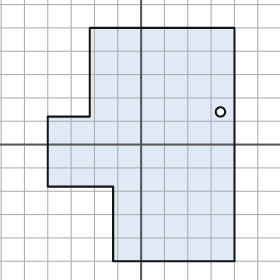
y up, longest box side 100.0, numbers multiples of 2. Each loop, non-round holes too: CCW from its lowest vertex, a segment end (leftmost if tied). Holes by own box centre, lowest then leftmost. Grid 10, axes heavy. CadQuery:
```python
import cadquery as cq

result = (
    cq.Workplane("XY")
    .moveTo(-12.0, -50.0)
    .lineTo(40.0, -50.0)
    .lineTo(40.0, 50.0)
    .lineTo(-22.0, 50.0)
    .lineTo(-22.0, 12.0)
    .lineTo(-40.0, 12.0)
    .lineTo(-40.0, -18.0)
    .lineTo(-12.0, -18.0)
    .close()
    .moveTo(34.0, 14.0)
    .circle(2.0)
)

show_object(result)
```